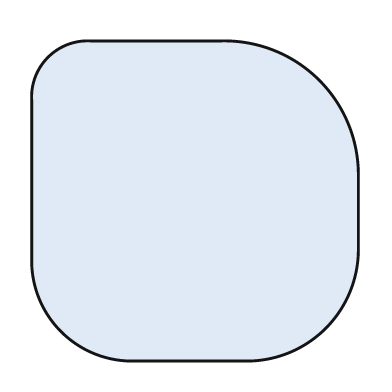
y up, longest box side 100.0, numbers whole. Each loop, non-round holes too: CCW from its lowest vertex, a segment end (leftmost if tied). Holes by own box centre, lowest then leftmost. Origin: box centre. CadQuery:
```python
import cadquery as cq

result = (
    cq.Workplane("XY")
    .moveTo(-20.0, -49.0)
    .lineTo(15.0, -49.0)
    .threePointArc((40.0, -39.0), (50.0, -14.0))
    .lineTo(50.0, 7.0)
    .threePointArc((38.0, 37.0), (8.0, 49.0))
    .lineTo(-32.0, 49.0)
    .threePointArc((-45.0, 44.0), (-50.0, 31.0))
    .lineTo(-50.0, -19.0)
    .threePointArc((-41.0, -40.0), (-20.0, -49.0))
    .close()
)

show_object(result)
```